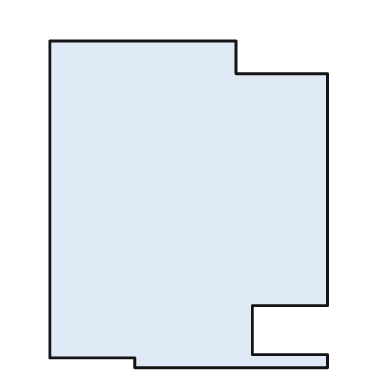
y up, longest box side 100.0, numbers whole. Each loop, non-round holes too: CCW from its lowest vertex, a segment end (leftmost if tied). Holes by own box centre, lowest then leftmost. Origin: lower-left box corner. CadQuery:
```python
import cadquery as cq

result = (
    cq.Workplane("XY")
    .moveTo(26.0, 0.0)
    .lineTo(85.0, 0.0)
    .lineTo(85.0, 4.0)
    .lineTo(62.0, 4.0)
    .lineTo(62.0, 19.0)
    .lineTo(85.0, 19.0)
    .lineTo(85.0, 90.0)
    .lineTo(57.0, 90.0)
    .lineTo(57.0, 100.0)
    .lineTo(0.0, 100.0)
    .lineTo(0.0, 3.0)
    .lineTo(26.0, 3.0)
    .close()
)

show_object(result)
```